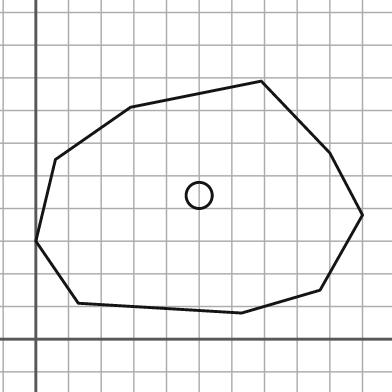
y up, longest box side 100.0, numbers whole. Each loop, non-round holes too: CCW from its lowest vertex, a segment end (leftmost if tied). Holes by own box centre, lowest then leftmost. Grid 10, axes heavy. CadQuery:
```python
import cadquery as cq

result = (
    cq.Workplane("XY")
    .moveTo(63.0, 8.0)
    .lineTo(87.0, 15.0)
    .lineTo(100.0, 38.0)
    .lineTo(90.0, 57.0)
    .lineTo(69.0, 79.0)
    .lineTo(29.0, 71.0)
    .lineTo(6.0, 55.0)
    .lineTo(0.0, 30.0)
    .lineTo(13.0, 11.0)
    .close()
    .moveTo(50.0, 44.0)
    .circle(4.0)
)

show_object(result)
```